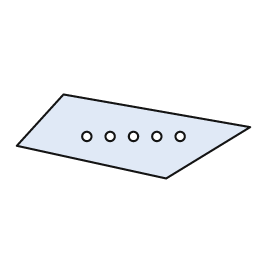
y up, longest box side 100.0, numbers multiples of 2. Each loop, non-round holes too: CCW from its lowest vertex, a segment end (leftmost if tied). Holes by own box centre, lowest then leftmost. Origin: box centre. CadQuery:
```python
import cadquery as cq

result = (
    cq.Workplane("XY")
    .moveTo(14.0, -18.0)
    .lineTo(50.0, 4.0)
    .lineTo(-30.0, 18.0)
    .lineTo(-50.0, -4.0)
    .close()
    .moveTo(-20.0, 0.0)
    .circle(2.0)
    .moveTo(-10.0, 0.0)
    .circle(2.0)
    .moveTo(0.0, 0.0)
    .circle(2.0)
    .moveTo(10.0, 0.0)
    .circle(2.0)
    .moveTo(20.0, 0.0)
    .circle(2.0)
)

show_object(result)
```